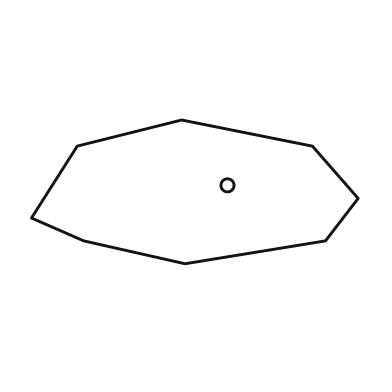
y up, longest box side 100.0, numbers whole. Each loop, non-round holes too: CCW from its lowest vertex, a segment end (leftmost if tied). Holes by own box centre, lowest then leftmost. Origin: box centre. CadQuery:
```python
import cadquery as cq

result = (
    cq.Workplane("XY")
    .moveTo(-3.0, -22.0)
    .lineTo(40.0, -15.0)
    .lineTo(50.0, -2.0)
    .lineTo(36.0, 14.0)
    .lineTo(-4.0, 22.0)
    .lineTo(-36.0, 14.0)
    .lineTo(-50.0, -8.0)
    .lineTo(-34.0, -15.0)
    .close()
    .moveTo(10.0, 2.0)
    .circle(2.0)
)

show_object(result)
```